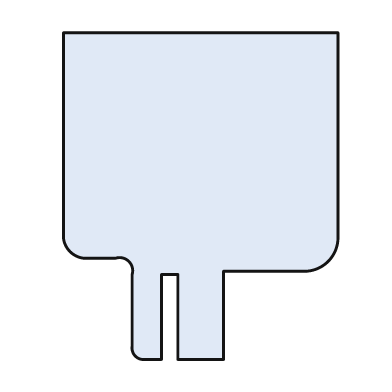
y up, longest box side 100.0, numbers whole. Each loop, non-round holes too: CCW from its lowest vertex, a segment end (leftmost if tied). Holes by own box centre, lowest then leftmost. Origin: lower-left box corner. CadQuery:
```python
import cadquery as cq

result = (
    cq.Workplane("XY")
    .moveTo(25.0, 0.0)
    .lineTo(30.0, 0.0)
    .lineTo(30.0, 26.0)
    .lineTo(35.0, 26.0)
    .lineTo(35.0, 0.0)
    .lineTo(49.0, 0.0)
    .lineTo(49.0, 27.0)
    .lineTo(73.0, 27.0)
    .threePointArc((81.0, 30.0), (84.0, 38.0))
    .lineTo(84.0, 100.0)
    .lineTo(0.0, 100.0)
    .lineTo(0.0, 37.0)
    .threePointArc((2.0, 33.0), (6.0, 31.0))
    .lineTo(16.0, 31.0)
    .threePointArc((20.0, 30.0), (21.0, 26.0))
    .lineTo(21.0, 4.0)
    .threePointArc((22.0, 1.0), (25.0, 0.0))
    .close()
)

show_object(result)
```